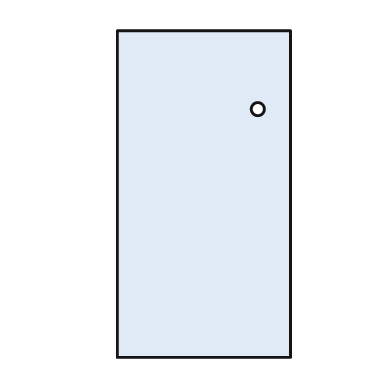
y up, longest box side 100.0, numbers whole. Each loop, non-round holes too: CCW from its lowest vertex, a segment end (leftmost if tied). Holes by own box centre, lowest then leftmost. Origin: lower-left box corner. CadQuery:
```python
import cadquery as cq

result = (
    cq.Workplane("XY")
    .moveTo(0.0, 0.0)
    .lineTo(53.0, 0.0)
    .lineTo(53.0, 100.0)
    .lineTo(0.0, 100.0)
    .close()
    .moveTo(43.0, 76.0)
    .circle(2.0)
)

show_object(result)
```